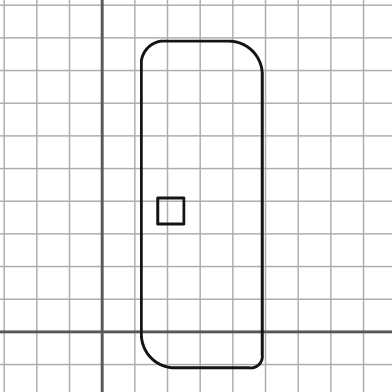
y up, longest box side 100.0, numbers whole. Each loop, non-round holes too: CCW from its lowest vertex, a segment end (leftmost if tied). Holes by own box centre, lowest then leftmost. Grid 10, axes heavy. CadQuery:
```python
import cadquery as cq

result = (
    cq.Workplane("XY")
    .moveTo(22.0, -11.0)
    .lineTo(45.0, -11.0)
    .threePointArc((48.0, -10.0), (49.0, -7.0))
    .lineTo(49.0, 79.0)
    .threePointArc((46.0, 86.0), (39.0, 89.0))
    .lineTo(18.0, 89.0)
    .threePointArc((14.0, 87.0), (12.0, 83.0))
    .lineTo(12.0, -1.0)
    .threePointArc((15.0, -8.0), (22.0, -11.0))
    .close()
    .moveTo(17.0, 33.0)
    .lineTo(25.0, 33.0)
    .lineTo(25.0, 41.0)
    .lineTo(17.0, 41.0)
    .close()
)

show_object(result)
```